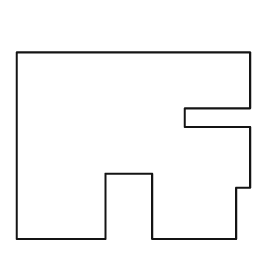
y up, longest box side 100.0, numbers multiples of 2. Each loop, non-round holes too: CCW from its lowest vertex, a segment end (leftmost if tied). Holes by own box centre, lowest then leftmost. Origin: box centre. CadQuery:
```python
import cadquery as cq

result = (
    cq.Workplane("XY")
    .moveTo(-50.0, -40.0)
    .lineTo(-12.0, -40.0)
    .lineTo(-12.0, -12.0)
    .lineTo(8.0, -12.0)
    .lineTo(8.0, -40.0)
    .lineTo(44.0, -40.0)
    .lineTo(44.0, -18.0)
    .lineTo(50.0, -18.0)
    .lineTo(50.0, 8.0)
    .lineTo(22.0, 8.0)
    .lineTo(22.0, 16.0)
    .lineTo(50.0, 16.0)
    .lineTo(50.0, 40.0)
    .lineTo(-50.0, 40.0)
    .close()
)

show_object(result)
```